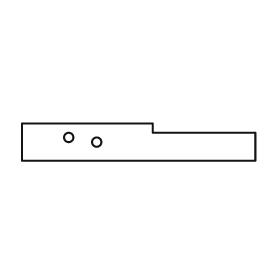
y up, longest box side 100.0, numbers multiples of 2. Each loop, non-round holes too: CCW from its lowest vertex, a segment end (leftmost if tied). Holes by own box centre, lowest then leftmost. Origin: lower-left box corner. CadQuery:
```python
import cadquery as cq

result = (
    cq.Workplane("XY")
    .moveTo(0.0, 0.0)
    .lineTo(100.0, 0.0)
    .lineTo(100.0, 12.0)
    .lineTo(56.0, 12.0)
    .lineTo(56.0, 16.0)
    .lineTo(0.0, 16.0)
    .close()
    .moveTo(32.0, 8.0)
    .circle(2.0)
    .moveTo(20.0, 10.0)
    .circle(2.0)
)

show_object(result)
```